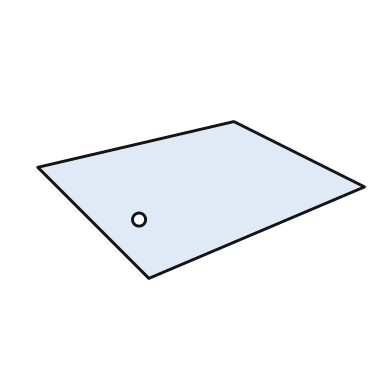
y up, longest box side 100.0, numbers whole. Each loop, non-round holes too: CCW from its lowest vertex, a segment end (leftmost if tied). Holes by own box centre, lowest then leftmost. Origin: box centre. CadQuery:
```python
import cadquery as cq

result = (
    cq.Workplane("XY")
    .moveTo(-16.0, -24.0)
    .lineTo(50.0, 4.0)
    .lineTo(10.0, 24.0)
    .lineTo(-50.0, 10.0)
    .close()
    .moveTo(-19.0, -6.0)
    .circle(2.0)
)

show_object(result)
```